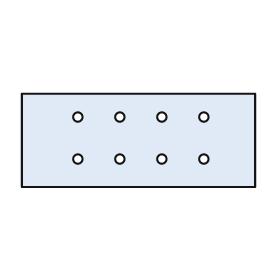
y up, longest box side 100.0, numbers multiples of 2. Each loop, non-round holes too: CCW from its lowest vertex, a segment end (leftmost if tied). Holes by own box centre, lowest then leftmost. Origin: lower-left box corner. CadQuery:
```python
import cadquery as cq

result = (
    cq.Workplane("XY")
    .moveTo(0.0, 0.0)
    .lineTo(100.0, 0.0)
    .lineTo(100.0, 40.0)
    .lineTo(0.0, 40.0)
    .close()
    .moveTo(24.0, 12.0)
    .circle(2.0)
    .moveTo(42.0, 12.0)
    .circle(2.0)
    .moveTo(60.0, 12.0)
    .circle(2.0)
    .moveTo(78.0, 12.0)
    .circle(2.0)
    .moveTo(24.0, 30.0)
    .circle(2.0)
    .moveTo(42.0, 30.0)
    .circle(2.0)
    .moveTo(60.0, 30.0)
    .circle(2.0)
    .moveTo(78.0, 30.0)
    .circle(2.0)
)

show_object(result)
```